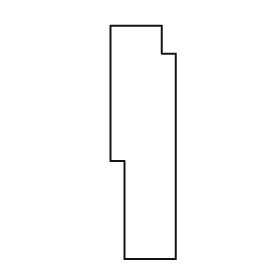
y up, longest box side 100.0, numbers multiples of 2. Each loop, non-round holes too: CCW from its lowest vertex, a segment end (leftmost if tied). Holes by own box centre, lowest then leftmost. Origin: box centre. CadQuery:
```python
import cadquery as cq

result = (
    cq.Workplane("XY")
    .moveTo(-8.0, -50.0)
    .lineTo(14.0, -50.0)
    .lineTo(14.0, 38.0)
    .lineTo(8.0, 38.0)
    .lineTo(8.0, 50.0)
    .lineTo(-14.0, 50.0)
    .lineTo(-14.0, -8.0)
    .lineTo(-8.0, -8.0)
    .close()
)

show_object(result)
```